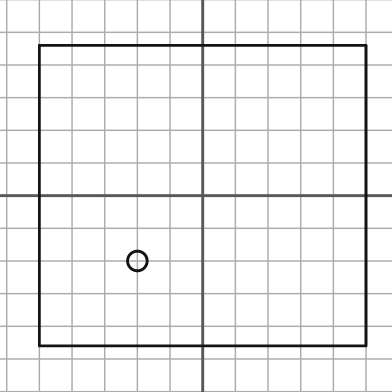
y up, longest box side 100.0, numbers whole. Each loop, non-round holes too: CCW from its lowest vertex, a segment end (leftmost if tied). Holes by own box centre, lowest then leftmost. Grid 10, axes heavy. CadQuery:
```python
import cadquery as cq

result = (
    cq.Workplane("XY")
    .moveTo(-50.0, -46.0)
    .lineTo(50.0, -46.0)
    .lineTo(50.0, 46.0)
    .lineTo(-50.0, 46.0)
    .close()
    .moveTo(-20.0, -20.0)
    .circle(3.0)
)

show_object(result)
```